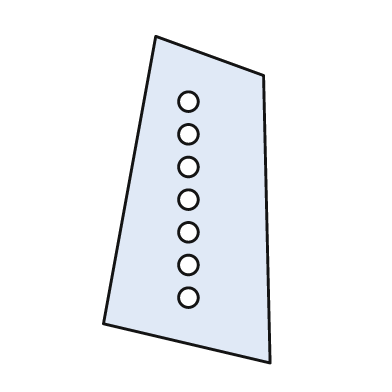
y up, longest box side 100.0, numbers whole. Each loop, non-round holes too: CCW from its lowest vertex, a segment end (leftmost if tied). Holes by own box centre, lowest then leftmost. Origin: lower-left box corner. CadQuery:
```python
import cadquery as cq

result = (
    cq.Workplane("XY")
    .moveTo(51.0, 0.0)
    .lineTo(49.0, 88.0)
    .lineTo(16.0, 100.0)
    .lineTo(0.0, 12.0)
    .close()
    .moveTo(26.0, 20.0)
    .circle(3.0)
    .moveTo(26.0, 30.0)
    .circle(3.0)
    .moveTo(26.0, 40.0)
    .circle(3.0)
    .moveTo(26.0, 50.0)
    .circle(3.0)
    .moveTo(26.0, 60.0)
    .circle(3.0)
    .moveTo(26.0, 70.0)
    .circle(3.0)
    .moveTo(26.0, 80.0)
    .circle(3.0)
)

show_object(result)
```